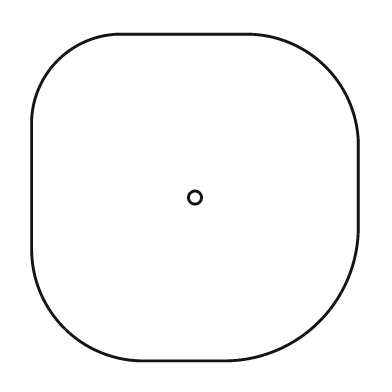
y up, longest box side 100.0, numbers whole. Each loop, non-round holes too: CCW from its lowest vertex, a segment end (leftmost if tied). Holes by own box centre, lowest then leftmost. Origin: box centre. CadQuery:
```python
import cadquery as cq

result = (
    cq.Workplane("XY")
    .moveTo(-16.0, -50.0)
    .lineTo(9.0, -50.0)
    .threePointArc((38.0, -38.0), (50.0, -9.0))
    .lineTo(50.0, 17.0)
    .threePointArc((40.0, 40.0), (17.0, 50.0))
    .lineTo(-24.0, 50.0)
    .threePointArc((-42.0, 42.0), (-50.0, 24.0))
    .lineTo(-50.0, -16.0)
    .threePointArc((-40.0, -40.0), (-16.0, -50.0))
    .close()
    .moveTo(0.0, 0.0)
    .circle(2.0)
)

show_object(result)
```